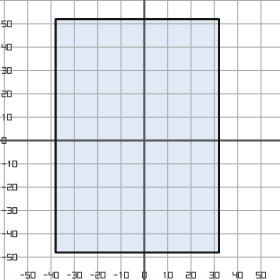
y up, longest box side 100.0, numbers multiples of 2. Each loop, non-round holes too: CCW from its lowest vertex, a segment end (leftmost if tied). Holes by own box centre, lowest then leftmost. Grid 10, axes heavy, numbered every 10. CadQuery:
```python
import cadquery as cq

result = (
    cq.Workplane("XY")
    .moveTo(-38.0, -48.0)
    .lineTo(32.0, -48.0)
    .lineTo(32.0, 52.0)
    .lineTo(-38.0, 52.0)
    .close()
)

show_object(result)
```